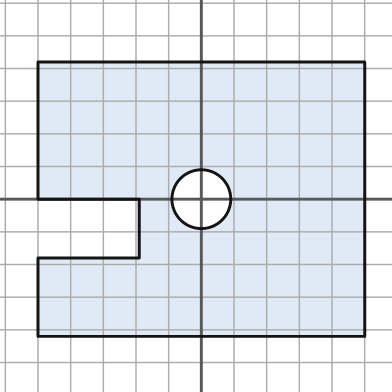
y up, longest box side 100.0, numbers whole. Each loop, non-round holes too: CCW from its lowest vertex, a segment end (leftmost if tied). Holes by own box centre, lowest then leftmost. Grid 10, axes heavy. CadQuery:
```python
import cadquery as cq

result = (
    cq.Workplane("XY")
    .moveTo(-50.0, -42.0)
    .lineTo(50.0, -42.0)
    .lineTo(50.0, 42.0)
    .lineTo(-50.0, 42.0)
    .lineTo(-50.0, 0.0)
    .lineTo(-19.0, 0.0)
    .lineTo(-19.0, -18.0)
    .lineTo(-50.0, -18.0)
    .close()
    .moveTo(0.0, 0.0)
    .circle(9.0)
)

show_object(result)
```